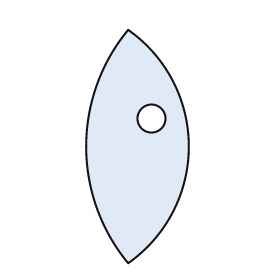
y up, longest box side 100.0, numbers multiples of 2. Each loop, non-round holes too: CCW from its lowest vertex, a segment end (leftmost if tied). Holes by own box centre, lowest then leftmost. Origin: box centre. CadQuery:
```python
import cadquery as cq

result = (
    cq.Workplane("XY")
    .moveTo(-4.0, -50.0)
    .threePointArc((22.0, 0.0), (-4.0, 50.0))
    .threePointArc((-22.0, 0.0), (-4.0, -50.0))
    .close()
    .moveTo(6.0, 12.0)
    .circle(6.0)
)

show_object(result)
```